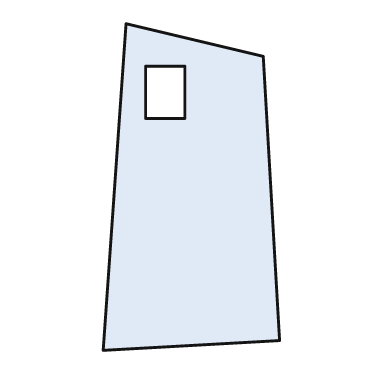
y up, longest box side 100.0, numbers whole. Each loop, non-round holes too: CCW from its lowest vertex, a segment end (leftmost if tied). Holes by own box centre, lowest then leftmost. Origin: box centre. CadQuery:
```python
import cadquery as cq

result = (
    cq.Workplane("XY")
    .moveTo(-27.0, -50.0)
    .lineTo(27.0, -47.0)
    .lineTo(22.0, 40.0)
    .lineTo(-20.0, 50.0)
    .close()
    .moveTo(-14.0, 21.0)
    .lineTo(-2.0, 21.0)
    .lineTo(-2.0, 37.0)
    .lineTo(-14.0, 37.0)
    .close()
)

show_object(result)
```